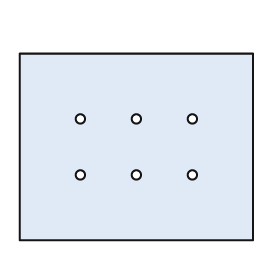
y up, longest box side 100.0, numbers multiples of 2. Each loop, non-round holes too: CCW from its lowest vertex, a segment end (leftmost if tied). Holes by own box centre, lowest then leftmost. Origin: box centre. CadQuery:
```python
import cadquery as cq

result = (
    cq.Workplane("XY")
    .moveTo(-50.0, -40.0)
    .lineTo(50.0, -40.0)
    .lineTo(50.0, 40.0)
    .lineTo(-50.0, 40.0)
    .close()
    .moveTo(-24.0, -12.0)
    .circle(2.0)
    .moveTo(0.0, -12.0)
    .circle(2.0)
    .moveTo(24.0, -12.0)
    .circle(2.0)
    .moveTo(-24.0, 12.0)
    .circle(2.0)
    .moveTo(0.0, 12.0)
    .circle(2.0)
    .moveTo(24.0, 12.0)
    .circle(2.0)
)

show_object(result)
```